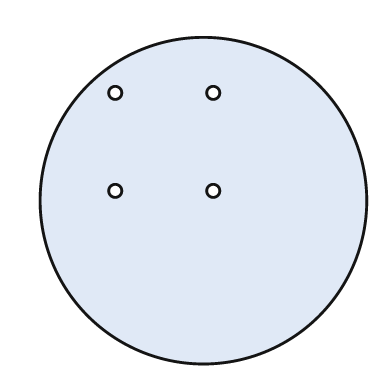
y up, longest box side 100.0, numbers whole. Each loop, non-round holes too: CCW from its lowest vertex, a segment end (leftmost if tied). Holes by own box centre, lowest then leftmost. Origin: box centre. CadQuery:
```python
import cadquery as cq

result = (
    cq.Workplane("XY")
    .moveTo(0.0, 0.0)
    .circle(50.0)
    .moveTo(-27.0, 3.0)
    .circle(2.0)
    .moveTo(3.0, 3.0)
    .circle(2.0)
    .moveTo(-27.0, 33.0)
    .circle(2.0)
    .moveTo(3.0, 33.0)
    .circle(2.0)
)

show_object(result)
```